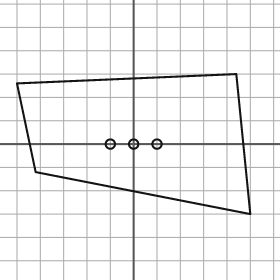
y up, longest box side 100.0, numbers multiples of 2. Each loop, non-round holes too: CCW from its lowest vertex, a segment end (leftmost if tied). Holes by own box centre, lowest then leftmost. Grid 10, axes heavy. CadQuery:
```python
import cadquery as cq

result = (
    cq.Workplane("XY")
    .moveTo(50.0, -30.0)
    .lineTo(44.0, 30.0)
    .lineTo(-50.0, 26.0)
    .lineTo(-42.0, -12.0)
    .close()
    .moveTo(-10.0, 0.0)
    .circle(2.0)
    .moveTo(0.0, 0.0)
    .circle(2.0)
    .moveTo(10.0, 0.0)
    .circle(2.0)
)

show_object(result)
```